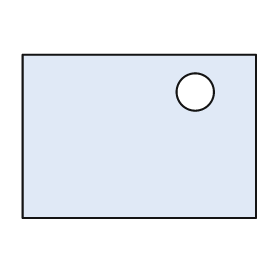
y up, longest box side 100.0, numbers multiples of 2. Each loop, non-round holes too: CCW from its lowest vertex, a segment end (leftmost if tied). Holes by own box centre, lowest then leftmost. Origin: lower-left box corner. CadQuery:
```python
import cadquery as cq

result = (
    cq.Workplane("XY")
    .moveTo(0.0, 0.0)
    .lineTo(100.0, 0.0)
    .lineTo(100.0, 70.0)
    .lineTo(0.0, 70.0)
    .close()
    .moveTo(74.0, 54.0)
    .circle(8.0)
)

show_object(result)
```